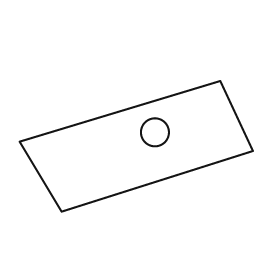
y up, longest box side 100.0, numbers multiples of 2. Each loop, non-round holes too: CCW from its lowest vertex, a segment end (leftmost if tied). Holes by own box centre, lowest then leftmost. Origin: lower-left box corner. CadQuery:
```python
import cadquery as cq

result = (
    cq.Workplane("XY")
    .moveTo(18.0, 0.0)
    .lineTo(100.0, 26.0)
    .lineTo(86.0, 56.0)
    .lineTo(0.0, 30.0)
    .close()
    .moveTo(58.0, 34.0)
    .circle(6.0)
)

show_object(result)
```